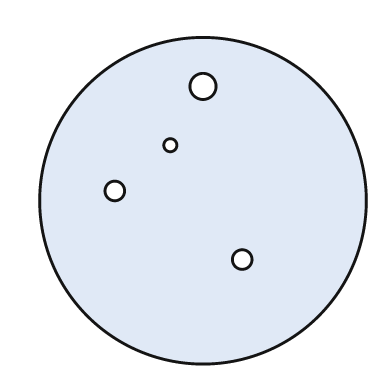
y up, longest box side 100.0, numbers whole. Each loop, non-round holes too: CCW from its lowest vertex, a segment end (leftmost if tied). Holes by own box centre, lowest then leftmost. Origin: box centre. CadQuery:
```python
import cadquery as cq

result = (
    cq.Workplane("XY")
    .moveTo(0.0, 0.0)
    .circle(50.0)
    .moveTo(12.0, -18.0)
    .circle(3.0)
    .moveTo(-27.0, 3.0)
    .circle(3.0)
    .moveTo(-10.0, 17.0)
    .circle(2.0)
    .moveTo(0.0, 35.0)
    .circle(4.0)
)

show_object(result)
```